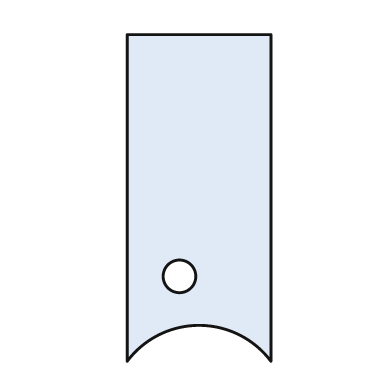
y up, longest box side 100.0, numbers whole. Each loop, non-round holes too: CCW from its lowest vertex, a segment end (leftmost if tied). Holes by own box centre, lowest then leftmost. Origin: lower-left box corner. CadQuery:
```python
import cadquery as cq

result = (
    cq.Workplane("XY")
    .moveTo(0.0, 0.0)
    .threePointArc((22.0, 11.0), (44.0, 0.0))
    .lineTo(44.0, 100.0)
    .lineTo(0.0, 100.0)
    .close()
    .moveTo(16.0, 26.0)
    .circle(5.0)
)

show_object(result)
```